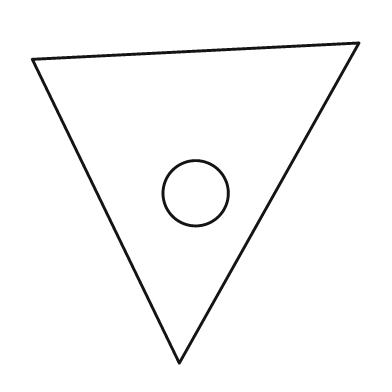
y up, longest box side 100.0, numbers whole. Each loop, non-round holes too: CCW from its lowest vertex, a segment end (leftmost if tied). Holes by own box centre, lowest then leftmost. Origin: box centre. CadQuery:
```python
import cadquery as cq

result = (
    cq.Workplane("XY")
    .moveTo(-5.0, -49.0)
    .lineTo(50.0, 49.0)
    .lineTo(-50.0, 44.0)
    .close()
    .moveTo(0.0, 3.0)
    .circle(10.0)
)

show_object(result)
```